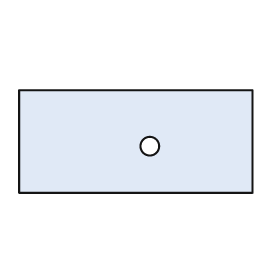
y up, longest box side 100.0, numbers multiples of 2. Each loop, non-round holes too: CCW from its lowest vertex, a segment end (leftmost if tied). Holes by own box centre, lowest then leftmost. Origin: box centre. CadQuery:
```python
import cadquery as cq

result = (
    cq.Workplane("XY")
    .moveTo(-50.0, -22.0)
    .lineTo(50.0, -22.0)
    .lineTo(50.0, 22.0)
    .lineTo(-50.0, 22.0)
    .close()
    .moveTo(6.0, -2.0)
    .circle(4.0)
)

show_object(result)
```